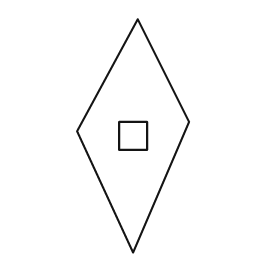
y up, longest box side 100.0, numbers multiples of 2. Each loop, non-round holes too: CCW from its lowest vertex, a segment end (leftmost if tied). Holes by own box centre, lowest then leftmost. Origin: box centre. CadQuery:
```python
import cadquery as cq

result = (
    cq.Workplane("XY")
    .moveTo(0.0, -50.0)
    .lineTo(24.0, 6.0)
    .lineTo(2.0, 50.0)
    .lineTo(-24.0, 2.0)
    .close()
    .moveTo(-6.0, -6.0)
    .lineTo(6.0, -6.0)
    .lineTo(6.0, 6.0)
    .lineTo(-6.0, 6.0)
    .close()
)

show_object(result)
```